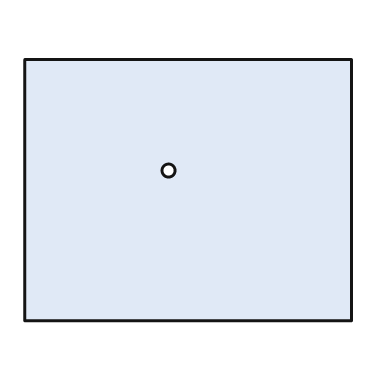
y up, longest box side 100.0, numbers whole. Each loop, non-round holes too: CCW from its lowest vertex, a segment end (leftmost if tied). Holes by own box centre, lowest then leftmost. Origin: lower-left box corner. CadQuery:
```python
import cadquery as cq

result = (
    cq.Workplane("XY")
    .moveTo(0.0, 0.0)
    .lineTo(100.0, 0.0)
    .lineTo(100.0, 80.0)
    .lineTo(0.0, 80.0)
    .close()
    .moveTo(44.0, 46.0)
    .circle(2.0)
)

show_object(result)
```